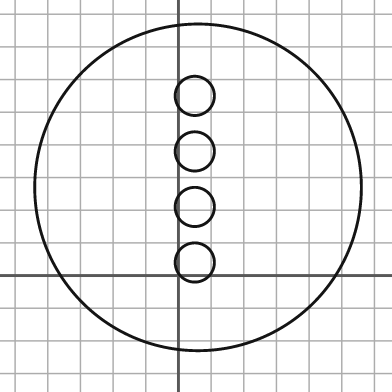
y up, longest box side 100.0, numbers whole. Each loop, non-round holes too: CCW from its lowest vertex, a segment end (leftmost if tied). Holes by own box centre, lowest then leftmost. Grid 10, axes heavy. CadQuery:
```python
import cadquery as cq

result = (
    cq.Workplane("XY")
    .moveTo(6.0, 27.0)
    .circle(50.0)
    .moveTo(5.0, 4.0)
    .circle(6.0)
    .moveTo(5.0, 21.0)
    .circle(6.0)
    .moveTo(5.0, 38.0)
    .circle(6.0)
    .moveTo(5.0, 55.0)
    .circle(6.0)
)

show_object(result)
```